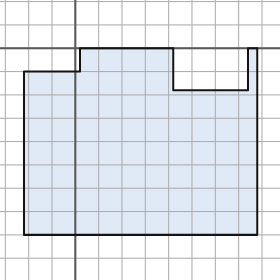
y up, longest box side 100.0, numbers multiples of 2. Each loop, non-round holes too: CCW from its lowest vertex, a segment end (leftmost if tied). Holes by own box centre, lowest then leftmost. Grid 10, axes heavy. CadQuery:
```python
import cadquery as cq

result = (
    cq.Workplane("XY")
    .moveTo(-22.0, -80.0)
    .lineTo(78.0, -80.0)
    .lineTo(78.0, 0.0)
    .lineTo(74.0, 0.0)
    .lineTo(74.0, -18.0)
    .lineTo(42.0, -18.0)
    .lineTo(42.0, 0.0)
    .lineTo(2.0, 0.0)
    .lineTo(2.0, -10.0)
    .lineTo(-22.0, -10.0)
    .close()
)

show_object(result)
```